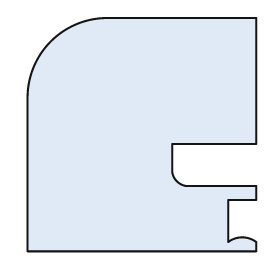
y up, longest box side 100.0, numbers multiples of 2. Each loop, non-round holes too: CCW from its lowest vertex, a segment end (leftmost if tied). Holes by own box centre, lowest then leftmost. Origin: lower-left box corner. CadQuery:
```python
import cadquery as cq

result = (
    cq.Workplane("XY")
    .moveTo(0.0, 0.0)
    .lineTo(98.0, 0.0)
    .lineTo(98.0, 4.0)
    .threePointArc((92.0, 6.0), (86.0, 4.0))
    .lineTo(86.0, 22.0)
    .lineTo(98.0, 22.0)
    .lineTo(98.0, 28.0)
    .lineTo(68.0, 28.0)
    .threePointArc((64.0, 30.0), (62.0, 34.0))
    .lineTo(62.0, 46.0)
    .lineTo(98.0, 46.0)
    .lineTo(98.0, 100.0)
    .lineTo(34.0, 100.0)
    .threePointArc((10.0, 90.0), (0.0, 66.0))
    .close()
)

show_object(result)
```